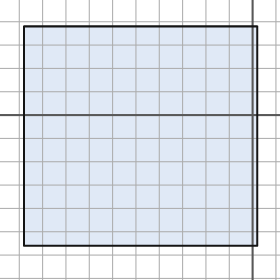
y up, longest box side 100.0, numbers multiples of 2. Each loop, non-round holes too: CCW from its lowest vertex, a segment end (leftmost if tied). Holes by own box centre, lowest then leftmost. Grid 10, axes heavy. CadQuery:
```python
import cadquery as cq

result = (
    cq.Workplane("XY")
    .moveTo(-98.0, -56.0)
    .lineTo(2.0, -56.0)
    .lineTo(2.0, 38.0)
    .lineTo(-98.0, 38.0)
    .close()
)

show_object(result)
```